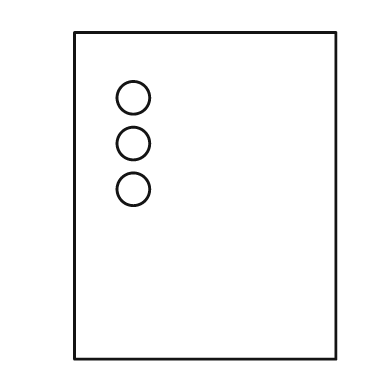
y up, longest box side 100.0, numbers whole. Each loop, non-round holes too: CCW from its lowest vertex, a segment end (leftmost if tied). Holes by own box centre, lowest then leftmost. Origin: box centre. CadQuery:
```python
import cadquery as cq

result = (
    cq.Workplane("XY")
    .moveTo(-40.0, -50.0)
    .lineTo(40.0, -50.0)
    .lineTo(40.0, 50.0)
    .lineTo(-40.0, 50.0)
    .close()
    .moveTo(-22.0, 2.0)
    .circle(5.0)
    .moveTo(-22.0, 16.0)
    .circle(5.0)
    .moveTo(-22.0, 30.0)
    .circle(5.0)
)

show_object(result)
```